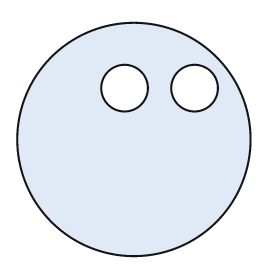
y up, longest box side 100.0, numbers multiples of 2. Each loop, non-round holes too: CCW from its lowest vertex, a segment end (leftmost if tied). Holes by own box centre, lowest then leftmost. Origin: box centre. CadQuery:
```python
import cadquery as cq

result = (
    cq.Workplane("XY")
    .moveTo(0.0, 0.0)
    .circle(50.0)
    .moveTo(-4.0, 22.0)
    .circle(10.0)
    .moveTo(26.0, 22.0)
    .circle(10.0)
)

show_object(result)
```